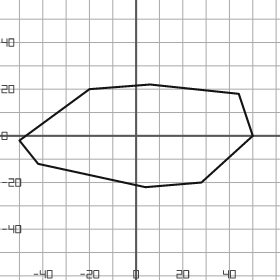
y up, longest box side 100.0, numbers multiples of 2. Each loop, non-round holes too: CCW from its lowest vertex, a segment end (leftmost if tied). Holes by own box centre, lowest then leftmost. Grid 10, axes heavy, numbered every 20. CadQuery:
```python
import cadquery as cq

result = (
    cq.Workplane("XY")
    .moveTo(4.0, -22.0)
    .lineTo(28.0, -20.0)
    .lineTo(50.0, 0.0)
    .lineTo(44.0, 18.0)
    .lineTo(6.0, 22.0)
    .lineTo(-20.0, 20.0)
    .lineTo(-50.0, -2.0)
    .lineTo(-42.0, -12.0)
    .close()
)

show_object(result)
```